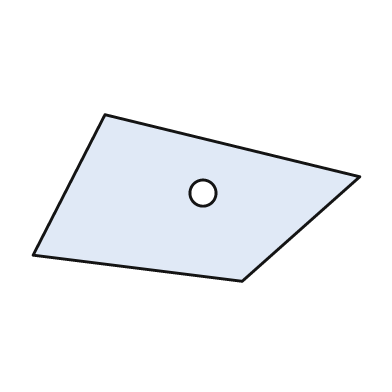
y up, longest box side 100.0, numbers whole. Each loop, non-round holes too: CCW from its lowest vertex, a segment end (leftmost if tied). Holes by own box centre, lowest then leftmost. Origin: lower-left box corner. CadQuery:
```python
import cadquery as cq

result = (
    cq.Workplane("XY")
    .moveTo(64.0, 0.0)
    .lineTo(100.0, 32.0)
    .lineTo(22.0, 51.0)
    .lineTo(0.0, 8.0)
    .close()
    .moveTo(52.0, 27.0)
    .circle(4.0)
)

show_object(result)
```